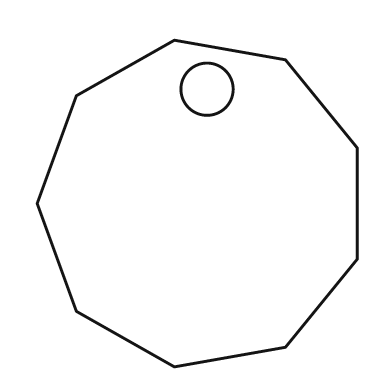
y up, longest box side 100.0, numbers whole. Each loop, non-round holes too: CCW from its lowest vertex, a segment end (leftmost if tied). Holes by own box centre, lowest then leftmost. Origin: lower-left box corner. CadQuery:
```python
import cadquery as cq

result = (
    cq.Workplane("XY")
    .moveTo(42.0, 0.0)
    .lineTo(76.0, 6.0)
    .lineTo(98.0, 33.0)
    .lineTo(98.0, 67.0)
    .lineTo(76.0, 94.0)
    .lineTo(42.0, 100.0)
    .lineTo(12.0, 83.0)
    .lineTo(0.0, 50.0)
    .lineTo(12.0, 17.0)
    .close()
    .moveTo(52.0, 85.0)
    .circle(8.0)
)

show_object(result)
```